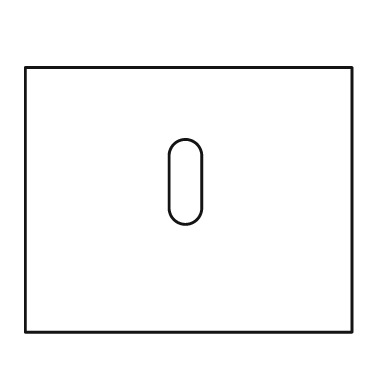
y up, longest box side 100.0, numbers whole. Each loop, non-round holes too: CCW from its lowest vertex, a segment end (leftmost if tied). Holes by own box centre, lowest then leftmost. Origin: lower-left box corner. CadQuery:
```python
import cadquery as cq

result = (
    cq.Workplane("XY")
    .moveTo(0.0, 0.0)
    .lineTo(100.0, 0.0)
    .lineTo(100.0, 81.0)
    .lineTo(0.0, 81.0)
    .close()
    .moveTo(44.0, 38.0)
    .threePointArc((49.0, 33.0), (54.0, 38.0))
    .lineTo(54.0, 54.0)
    .threePointArc((49.0, 59.0), (44.0, 54.0))
    .close()
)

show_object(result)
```